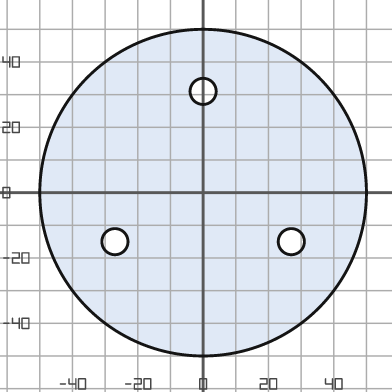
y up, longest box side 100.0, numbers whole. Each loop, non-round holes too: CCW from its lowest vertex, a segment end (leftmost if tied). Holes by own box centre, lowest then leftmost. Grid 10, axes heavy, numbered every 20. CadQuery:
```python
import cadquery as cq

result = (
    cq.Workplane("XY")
    .moveTo(0.0, 0.0)
    .circle(50.0)
    .moveTo(-27.0, -15.0)
    .circle(4.0)
    .moveTo(27.0, -15.0)
    .circle(4.0)
    .moveTo(0.0, 31.0)
    .circle(4.0)
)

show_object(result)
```